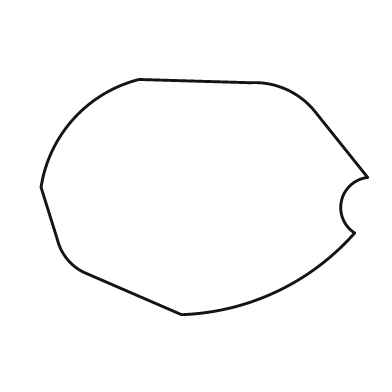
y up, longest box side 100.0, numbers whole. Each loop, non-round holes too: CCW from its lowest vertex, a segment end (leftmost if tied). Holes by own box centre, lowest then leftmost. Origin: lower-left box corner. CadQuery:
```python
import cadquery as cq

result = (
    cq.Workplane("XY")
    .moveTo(43.0, 0.0)
    .threePointArc((72.0, 7.0), (96.0, 25.0))
    .threePointArc((92.0, 35.0), (100.0, 42.0))
    .lineTo(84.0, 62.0)
    .threePointArc((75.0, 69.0), (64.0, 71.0))
    .lineTo(30.0, 72.0)
    .threePointArc((10.0, 60.0), (0.0, 39.0))
    .lineTo(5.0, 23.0)
    .threePointArc((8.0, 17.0), (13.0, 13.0))
    .close()
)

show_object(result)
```